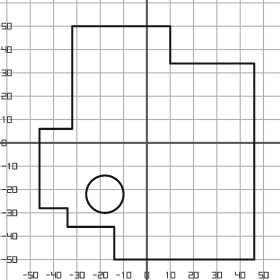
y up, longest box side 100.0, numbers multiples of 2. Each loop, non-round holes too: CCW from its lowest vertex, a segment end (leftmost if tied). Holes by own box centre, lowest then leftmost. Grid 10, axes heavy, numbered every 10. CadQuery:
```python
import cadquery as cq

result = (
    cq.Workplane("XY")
    .moveTo(-14.0, -50.0)
    .lineTo(46.0, -50.0)
    .lineTo(46.0, 34.0)
    .lineTo(10.0, 34.0)
    .lineTo(10.0, 50.0)
    .lineTo(-32.0, 50.0)
    .lineTo(-32.0, 6.0)
    .lineTo(-46.0, 6.0)
    .lineTo(-46.0, -28.0)
    .lineTo(-34.0, -28.0)
    .lineTo(-34.0, -36.0)
    .lineTo(-14.0, -36.0)
    .close()
    .moveTo(-18.0, -22.0)
    .circle(8.0)
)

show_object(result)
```